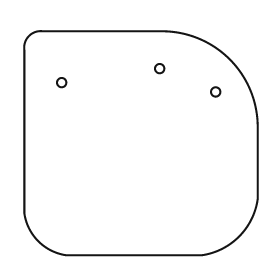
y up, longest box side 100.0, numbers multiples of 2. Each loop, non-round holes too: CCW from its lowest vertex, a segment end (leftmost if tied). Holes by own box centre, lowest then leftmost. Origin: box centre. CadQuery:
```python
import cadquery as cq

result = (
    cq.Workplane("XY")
    .moveTo(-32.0, -48.0)
    .lineTo(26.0, -48.0)
    .threePointArc((42.0, -40.0), (50.0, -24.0))
    .lineTo(50.0, 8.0)
    .threePointArc((38.0, 36.0), (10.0, 48.0))
    .lineTo(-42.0, 48.0)
    .threePointArc((-48.0, 46.0), (-50.0, 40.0))
    .lineTo(-50.0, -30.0)
    .threePointArc((-44.0, -42.0), (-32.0, -48.0))
    .close()
    .moveTo(32.0, 22.0)
    .circle(2.0)
    .moveTo(-34.0, 26.0)
    .circle(2.0)
    .moveTo(8.0, 32.0)
    .circle(2.0)
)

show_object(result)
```